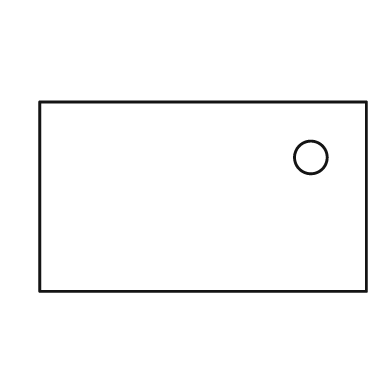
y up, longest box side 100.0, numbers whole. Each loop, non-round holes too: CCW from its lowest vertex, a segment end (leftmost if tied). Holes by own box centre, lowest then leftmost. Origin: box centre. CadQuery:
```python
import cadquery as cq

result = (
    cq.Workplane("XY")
    .moveTo(-50.0, -29.0)
    .lineTo(50.0, -29.0)
    .lineTo(50.0, 29.0)
    .lineTo(-50.0, 29.0)
    .close()
    .moveTo(33.0, 12.0)
    .circle(5.0)
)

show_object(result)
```